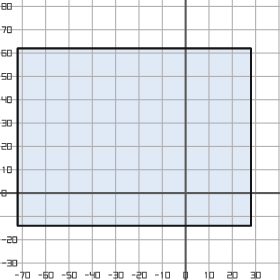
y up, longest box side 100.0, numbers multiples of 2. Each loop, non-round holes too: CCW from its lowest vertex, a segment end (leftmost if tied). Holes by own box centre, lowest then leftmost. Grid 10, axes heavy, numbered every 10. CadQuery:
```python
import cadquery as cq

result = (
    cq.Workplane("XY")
    .moveTo(-72.0, -14.0)
    .lineTo(28.0, -14.0)
    .lineTo(28.0, 62.0)
    .lineTo(-72.0, 62.0)
    .close()
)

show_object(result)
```